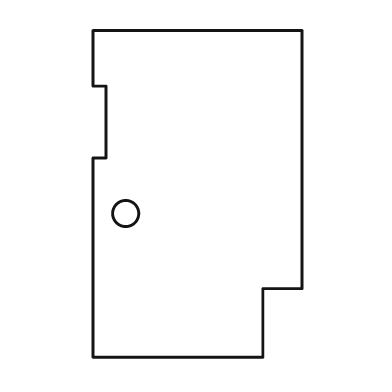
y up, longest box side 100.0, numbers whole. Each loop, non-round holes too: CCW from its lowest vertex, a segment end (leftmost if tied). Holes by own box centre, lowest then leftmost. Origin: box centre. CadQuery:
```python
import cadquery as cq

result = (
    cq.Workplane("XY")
    .moveTo(-32.0, -50.0)
    .lineTo(20.0, -50.0)
    .lineTo(20.0, -29.0)
    .lineTo(32.0, -29.0)
    .lineTo(32.0, 50.0)
    .lineTo(-32.0, 50.0)
    .lineTo(-32.0, 33.0)
    .lineTo(-28.0, 33.0)
    .lineTo(-28.0, 11.0)
    .lineTo(-32.0, 11.0)
    .close()
    .moveTo(-22.0, -6.0)
    .circle(4.0)
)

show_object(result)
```